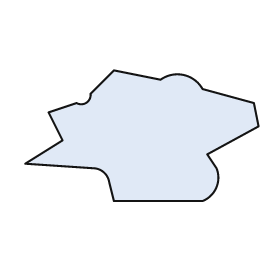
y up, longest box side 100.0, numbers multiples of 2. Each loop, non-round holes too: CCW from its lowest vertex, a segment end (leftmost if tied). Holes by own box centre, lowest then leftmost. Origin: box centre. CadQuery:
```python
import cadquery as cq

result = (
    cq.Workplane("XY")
    .moveTo(-12.0, -28.0)
    .lineTo(26.0, -28.0)
    .threePointArc((32.0, -22.0), (32.0, -14.0))
    .lineTo(28.0, -8.0)
    .lineTo(50.0, 4.0)
    .lineTo(48.0, 14.0)
    .lineTo(26.0, 20.0)
    .threePointArc((18.0, 26.0), (8.0, 24.0))
    .lineTo(-12.0, 28.0)
    .lineTo(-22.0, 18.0)
    .threePointArc((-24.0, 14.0), (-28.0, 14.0))
    .lineTo(-40.0, 10.0)
    .lineTo(-34.0, -2.0)
    .lineTo(-50.0, -12.0)
    .lineTo(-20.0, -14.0)
    .threePointArc((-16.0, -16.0), (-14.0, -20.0))
    .close()
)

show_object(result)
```